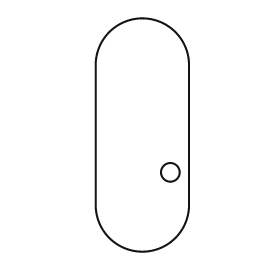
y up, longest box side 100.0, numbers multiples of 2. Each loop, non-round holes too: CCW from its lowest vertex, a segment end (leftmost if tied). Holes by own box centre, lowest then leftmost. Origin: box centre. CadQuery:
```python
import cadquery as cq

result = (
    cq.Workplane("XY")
    .moveTo(-20.0, -30.0)
    .threePointArc((0.0, -50.0), (20.0, -30.0))
    .lineTo(20.0, 30.0)
    .threePointArc((0.0, 50.0), (-20.0, 30.0))
    .close()
    .moveTo(12.0, -16.0)
    .circle(4.0)
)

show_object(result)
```